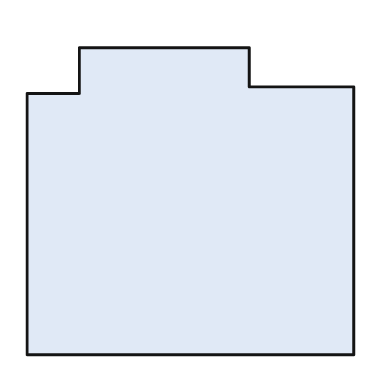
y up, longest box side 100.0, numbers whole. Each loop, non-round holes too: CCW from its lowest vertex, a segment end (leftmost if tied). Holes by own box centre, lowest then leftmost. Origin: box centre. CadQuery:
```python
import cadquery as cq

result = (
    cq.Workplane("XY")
    .moveTo(-50.0, -47.0)
    .lineTo(50.0, -47.0)
    .lineTo(50.0, 35.0)
    .lineTo(18.0, 35.0)
    .lineTo(18.0, 47.0)
    .lineTo(-34.0, 47.0)
    .lineTo(-34.0, 33.0)
    .lineTo(-50.0, 33.0)
    .close()
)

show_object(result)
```